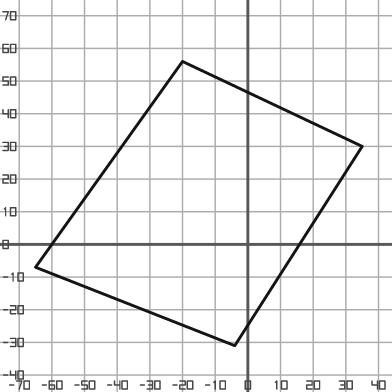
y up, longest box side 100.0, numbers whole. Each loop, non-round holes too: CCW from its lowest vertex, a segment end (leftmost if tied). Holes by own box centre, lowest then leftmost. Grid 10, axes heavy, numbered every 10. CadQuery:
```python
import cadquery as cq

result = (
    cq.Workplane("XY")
    .moveTo(-4.0, -31.0)
    .lineTo(35.0, 30.0)
    .lineTo(-20.0, 56.0)
    .lineTo(-65.0, -7.0)
    .close()
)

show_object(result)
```